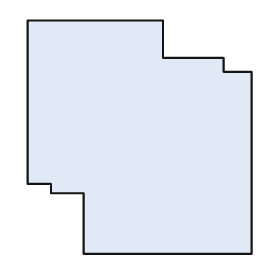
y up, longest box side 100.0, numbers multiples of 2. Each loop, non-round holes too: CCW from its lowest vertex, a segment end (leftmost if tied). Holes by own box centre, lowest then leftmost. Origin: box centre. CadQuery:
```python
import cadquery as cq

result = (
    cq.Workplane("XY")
    .moveTo(-24.0, -50.0)
    .lineTo(48.0, -50.0)
    .lineTo(48.0, 28.0)
    .lineTo(36.0, 28.0)
    .lineTo(36.0, 34.0)
    .lineTo(10.0, 34.0)
    .lineTo(10.0, 50.0)
    .lineTo(-48.0, 50.0)
    .lineTo(-48.0, -20.0)
    .lineTo(-38.0, -20.0)
    .lineTo(-38.0, -24.0)
    .lineTo(-24.0, -24.0)
    .close()
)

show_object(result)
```